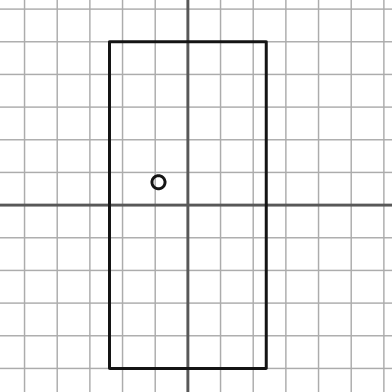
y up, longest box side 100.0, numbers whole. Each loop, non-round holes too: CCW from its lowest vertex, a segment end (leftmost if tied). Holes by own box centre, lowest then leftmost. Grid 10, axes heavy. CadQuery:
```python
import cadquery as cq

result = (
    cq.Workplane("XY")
    .moveTo(-24.0, -50.0)
    .lineTo(24.0, -50.0)
    .lineTo(24.0, 50.0)
    .lineTo(-24.0, 50.0)
    .close()
    .moveTo(-9.0, 7.0)
    .circle(2.0)
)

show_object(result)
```